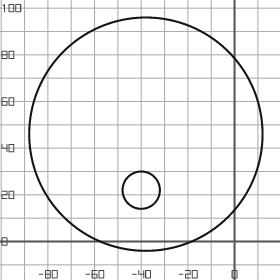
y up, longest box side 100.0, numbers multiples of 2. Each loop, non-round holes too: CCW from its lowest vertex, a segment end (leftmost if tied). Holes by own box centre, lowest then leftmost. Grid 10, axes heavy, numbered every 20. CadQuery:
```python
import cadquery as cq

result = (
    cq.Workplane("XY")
    .moveTo(-38.0, 46.0)
    .circle(50.0)
    .moveTo(-40.0, 22.0)
    .circle(8.0)
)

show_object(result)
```